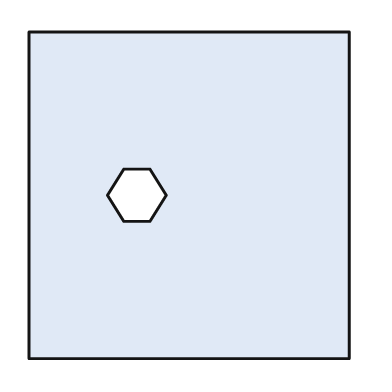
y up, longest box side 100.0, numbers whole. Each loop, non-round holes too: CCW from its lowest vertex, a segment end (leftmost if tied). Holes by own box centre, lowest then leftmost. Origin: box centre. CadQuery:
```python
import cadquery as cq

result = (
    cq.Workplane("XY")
    .moveTo(-49.0, -50.0)
    .lineTo(49.0, -50.0)
    .lineTo(49.0, 50.0)
    .lineTo(-49.0, 50.0)
    .close()
    .moveTo(-20.0, -8.0)
    .lineTo(-12.0, -8.0)
    .lineTo(-7.0, 0.0)
    .lineTo(-12.0, 8.0)
    .lineTo(-20.0, 8.0)
    .lineTo(-25.0, 0.0)
    .close()
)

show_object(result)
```